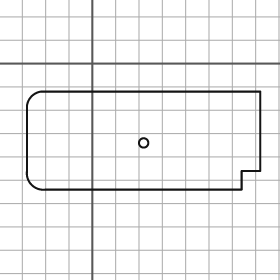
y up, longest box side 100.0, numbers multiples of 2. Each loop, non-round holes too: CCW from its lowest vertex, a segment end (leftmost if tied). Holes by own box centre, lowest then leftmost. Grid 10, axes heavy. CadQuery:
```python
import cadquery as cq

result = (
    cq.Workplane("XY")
    .moveTo(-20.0, -54.0)
    .lineTo(64.0, -54.0)
    .lineTo(64.0, -46.0)
    .lineTo(72.0, -46.0)
    .lineTo(72.0, -12.0)
    .lineTo(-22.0, -12.0)
    .threePointArc((-26.0, -14.0), (-28.0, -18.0))
    .lineTo(-28.0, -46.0)
    .threePointArc((-26.0, -52.0), (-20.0, -54.0))
    .close()
    .moveTo(22.0, -34.0)
    .circle(2.0)
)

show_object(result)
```